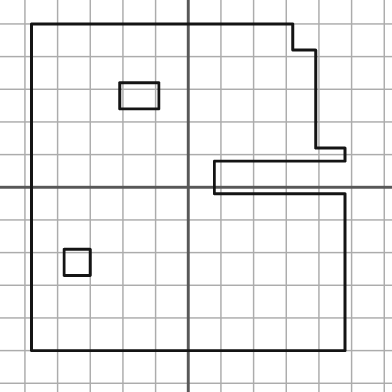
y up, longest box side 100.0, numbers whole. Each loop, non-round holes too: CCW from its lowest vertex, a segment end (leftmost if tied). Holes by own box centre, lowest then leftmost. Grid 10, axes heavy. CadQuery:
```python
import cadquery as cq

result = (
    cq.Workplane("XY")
    .moveTo(-48.0, -50.0)
    .lineTo(48.0, -50.0)
    .lineTo(48.0, -2.0)
    .lineTo(8.0, -2.0)
    .lineTo(8.0, 8.0)
    .lineTo(48.0, 8.0)
    .lineTo(48.0, 12.0)
    .lineTo(39.0, 12.0)
    .lineTo(39.0, 42.0)
    .lineTo(32.0, 42.0)
    .lineTo(32.0, 50.0)
    .lineTo(-48.0, 50.0)
    .close()
    .moveTo(-38.0, -27.0)
    .lineTo(-30.0, -27.0)
    .lineTo(-30.0, -19.0)
    .lineTo(-38.0, -19.0)
    .close()
    .moveTo(-21.0, 24.0)
    .lineTo(-9.0, 24.0)
    .lineTo(-9.0, 32.0)
    .lineTo(-21.0, 32.0)
    .close()
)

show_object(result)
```